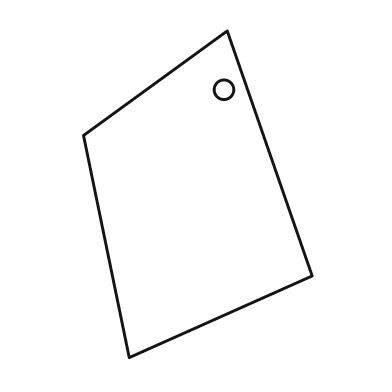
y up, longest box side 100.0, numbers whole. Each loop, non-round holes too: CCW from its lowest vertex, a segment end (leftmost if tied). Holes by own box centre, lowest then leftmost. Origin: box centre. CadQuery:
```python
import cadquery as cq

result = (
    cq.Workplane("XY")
    .moveTo(-21.0, -50.0)
    .lineTo(35.0, -25.0)
    .lineTo(9.0, 50.0)
    .lineTo(-35.0, 18.0)
    .close()
    .moveTo(8.0, 32.0)
    .circle(3.0)
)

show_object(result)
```